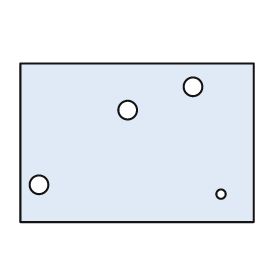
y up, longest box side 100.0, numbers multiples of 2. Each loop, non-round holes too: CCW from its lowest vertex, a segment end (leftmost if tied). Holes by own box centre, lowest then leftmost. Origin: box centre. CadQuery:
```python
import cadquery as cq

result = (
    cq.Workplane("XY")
    .moveTo(-50.0, -34.0)
    .lineTo(50.0, -34.0)
    .lineTo(50.0, 34.0)
    .lineTo(-50.0, 34.0)
    .close()
    .moveTo(36.0, -22.0)
    .circle(2.0)
    .moveTo(-42.0, -18.0)
    .circle(4.0)
    .moveTo(-4.0, 14.0)
    .circle(4.0)
    .moveTo(24.0, 24.0)
    .circle(4.0)
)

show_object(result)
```